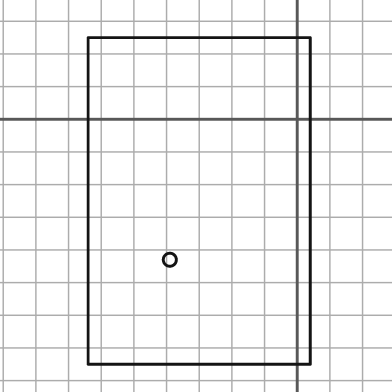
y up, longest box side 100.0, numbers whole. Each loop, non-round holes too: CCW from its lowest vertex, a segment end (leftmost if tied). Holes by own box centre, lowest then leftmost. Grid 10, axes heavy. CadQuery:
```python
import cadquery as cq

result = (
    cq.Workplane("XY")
    .moveTo(-64.0, -75.0)
    .lineTo(4.0, -75.0)
    .lineTo(4.0, 25.0)
    .lineTo(-64.0, 25.0)
    .close()
    .moveTo(-39.0, -43.0)
    .circle(2.0)
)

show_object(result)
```